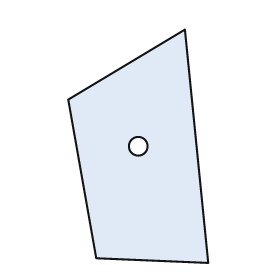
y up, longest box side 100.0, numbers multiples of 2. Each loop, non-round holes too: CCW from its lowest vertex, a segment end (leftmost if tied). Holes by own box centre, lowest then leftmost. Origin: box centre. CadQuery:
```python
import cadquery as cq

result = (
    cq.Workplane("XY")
    .moveTo(30.0, -50.0)
    .lineTo(20.0, 50.0)
    .lineTo(-30.0, 20.0)
    .lineTo(-18.0, -48.0)
    .close()
    .moveTo(0.0, 0.0)
    .circle(4.0)
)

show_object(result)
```